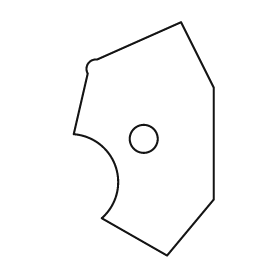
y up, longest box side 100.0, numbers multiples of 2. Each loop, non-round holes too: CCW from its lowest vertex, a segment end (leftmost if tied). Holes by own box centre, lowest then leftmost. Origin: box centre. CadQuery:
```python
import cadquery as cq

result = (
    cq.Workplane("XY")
    .moveTo(10.0, -50.0)
    .lineTo(30.0, -26.0)
    .lineTo(30.0, 22.0)
    .lineTo(16.0, 50.0)
    .lineTo(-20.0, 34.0)
    .threePointArc((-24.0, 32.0), (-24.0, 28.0))
    .lineTo(-30.0, 2.0)
    .threePointArc((-12.0, -12.0), (-18.0, -34.0))
    .close()
    .moveTo(0.0, 0.0)
    .circle(6.0)
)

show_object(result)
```